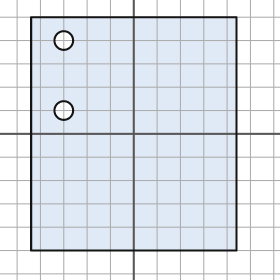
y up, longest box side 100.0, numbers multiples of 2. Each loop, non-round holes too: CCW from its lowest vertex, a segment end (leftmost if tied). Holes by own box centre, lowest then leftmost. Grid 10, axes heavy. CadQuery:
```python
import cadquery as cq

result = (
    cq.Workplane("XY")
    .moveTo(-44.0, -50.0)
    .lineTo(44.0, -50.0)
    .lineTo(44.0, 50.0)
    .lineTo(-44.0, 50.0)
    .close()
    .moveTo(-30.0, 10.0)
    .circle(4.0)
    .moveTo(-30.0, 40.0)
    .circle(4.0)
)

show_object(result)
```